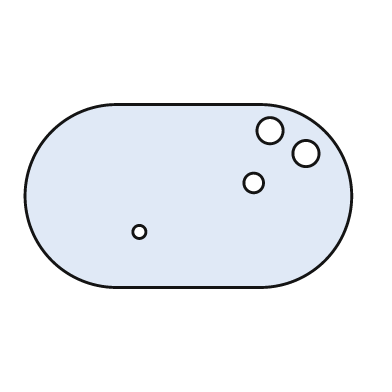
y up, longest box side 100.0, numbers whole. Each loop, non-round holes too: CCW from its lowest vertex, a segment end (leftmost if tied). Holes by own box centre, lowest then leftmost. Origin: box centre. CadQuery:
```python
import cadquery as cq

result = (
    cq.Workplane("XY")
    .moveTo(-22.0, -28.0)
    .lineTo(22.0, -28.0)
    .threePointArc((50.0, 0.0), (22.0, 28.0))
    .lineTo(-22.0, 28.0)
    .threePointArc((-50.0, 0.0), (-22.0, -28.0))
    .close()
    .moveTo(-15.0, -11.0)
    .circle(2.0)
    .moveTo(20.0, 4.0)
    .circle(3.0)
    .moveTo(36.0, 13.0)
    .circle(4.0)
    .moveTo(25.0, 20.0)
    .circle(4.0)
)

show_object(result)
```